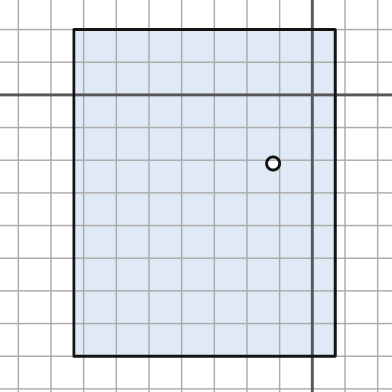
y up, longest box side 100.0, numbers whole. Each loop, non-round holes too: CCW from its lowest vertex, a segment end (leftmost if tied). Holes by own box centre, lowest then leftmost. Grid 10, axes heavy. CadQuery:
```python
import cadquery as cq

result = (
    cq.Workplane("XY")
    .moveTo(-73.0, -80.0)
    .lineTo(7.0, -80.0)
    .lineTo(7.0, 20.0)
    .lineTo(-73.0, 20.0)
    .close()
    .moveTo(-12.0, -21.0)
    .circle(2.0)
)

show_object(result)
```